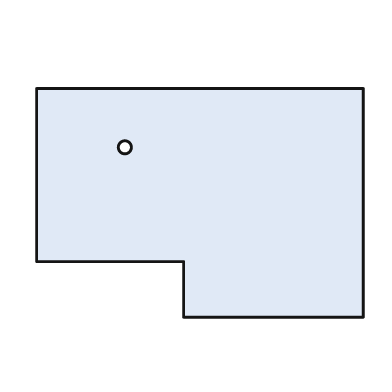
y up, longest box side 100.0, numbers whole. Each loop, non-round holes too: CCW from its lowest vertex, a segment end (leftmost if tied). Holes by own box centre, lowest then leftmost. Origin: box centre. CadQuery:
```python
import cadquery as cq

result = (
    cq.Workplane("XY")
    .moveTo(-5.0, -35.0)
    .lineTo(50.0, -35.0)
    .lineTo(50.0, 35.0)
    .lineTo(-50.0, 35.0)
    .lineTo(-50.0, -18.0)
    .lineTo(-5.0, -18.0)
    .close()
    .moveTo(-23.0, 17.0)
    .circle(2.0)
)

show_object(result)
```